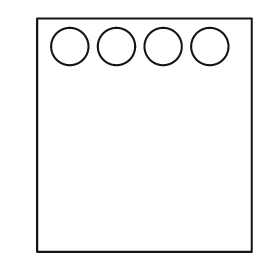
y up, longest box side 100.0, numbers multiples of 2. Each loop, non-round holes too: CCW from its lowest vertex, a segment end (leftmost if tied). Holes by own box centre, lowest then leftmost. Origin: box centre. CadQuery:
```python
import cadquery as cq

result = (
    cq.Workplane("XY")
    .moveTo(-46.0, -50.0)
    .lineTo(46.0, -50.0)
    .lineTo(46.0, 50.0)
    .lineTo(-46.0, 50.0)
    .close()
    .moveTo(-32.0, 38.0)
    .circle(8.0)
    .moveTo(-12.0, 38.0)
    .circle(8.0)
    .moveTo(8.0, 38.0)
    .circle(8.0)
    .moveTo(28.0, 38.0)
    .circle(8.0)
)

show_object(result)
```